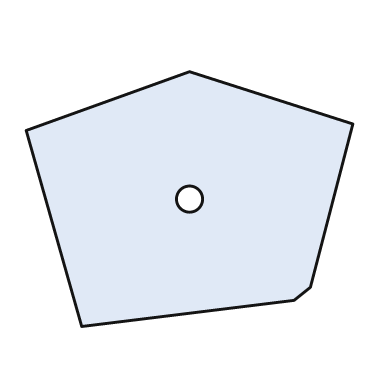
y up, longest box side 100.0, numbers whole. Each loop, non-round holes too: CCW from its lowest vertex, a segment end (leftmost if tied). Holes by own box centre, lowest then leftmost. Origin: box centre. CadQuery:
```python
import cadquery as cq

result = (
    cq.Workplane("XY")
    .moveTo(-33.0, -39.0)
    .lineTo(32.0, -31.0)
    .lineTo(37.0, -27.0)
    .lineTo(50.0, 23.0)
    .lineTo(0.0, 39.0)
    .lineTo(-50.0, 21.0)
    .close()
    .moveTo(0.0, 0.0)
    .circle(4.0)
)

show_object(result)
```